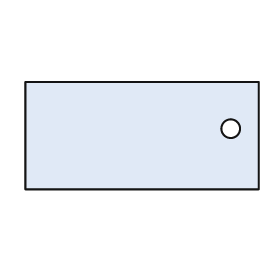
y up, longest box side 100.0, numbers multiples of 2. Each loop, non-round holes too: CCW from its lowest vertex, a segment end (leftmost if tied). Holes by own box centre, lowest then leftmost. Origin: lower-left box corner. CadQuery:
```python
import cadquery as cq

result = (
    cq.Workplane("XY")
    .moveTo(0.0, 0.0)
    .lineTo(100.0, 0.0)
    .lineTo(100.0, 46.0)
    .lineTo(0.0, 46.0)
    .close()
    .moveTo(88.0, 26.0)
    .circle(4.0)
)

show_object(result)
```